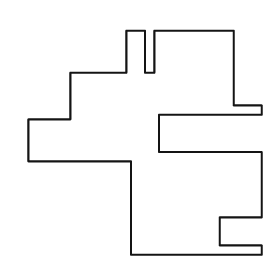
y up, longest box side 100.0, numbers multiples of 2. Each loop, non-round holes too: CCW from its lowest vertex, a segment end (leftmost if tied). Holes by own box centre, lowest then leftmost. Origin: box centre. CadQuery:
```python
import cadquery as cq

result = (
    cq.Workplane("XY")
    .moveTo(-6.0, -48.0)
    .lineTo(50.0, -48.0)
    .lineTo(50.0, -44.0)
    .lineTo(32.0, -44.0)
    .lineTo(32.0, -32.0)
    .lineTo(50.0, -32.0)
    .lineTo(50.0, -4.0)
    .lineTo(6.0, -4.0)
    .lineTo(6.0, 12.0)
    .lineTo(50.0, 12.0)
    .lineTo(50.0, 16.0)
    .lineTo(38.0, 16.0)
    .lineTo(38.0, 48.0)
    .lineTo(4.0, 48.0)
    .lineTo(4.0, 30.0)
    .lineTo(0.0, 30.0)
    .lineTo(0.0, 48.0)
    .lineTo(-8.0, 48.0)
    .lineTo(-8.0, 30.0)
    .lineTo(-32.0, 30.0)
    .lineTo(-32.0, 10.0)
    .lineTo(-50.0, 10.0)
    .lineTo(-50.0, -8.0)
    .lineTo(-6.0, -8.0)
    .close()
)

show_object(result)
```